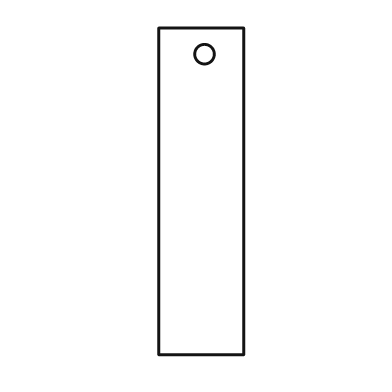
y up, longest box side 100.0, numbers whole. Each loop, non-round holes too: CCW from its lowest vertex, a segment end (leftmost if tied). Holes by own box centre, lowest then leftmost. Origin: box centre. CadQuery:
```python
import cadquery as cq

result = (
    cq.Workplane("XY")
    .moveTo(-13.0, -50.0)
    .lineTo(13.0, -50.0)
    .lineTo(13.0, 50.0)
    .lineTo(-13.0, 50.0)
    .close()
    .moveTo(1.0, 42.0)
    .circle(3.0)
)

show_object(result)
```